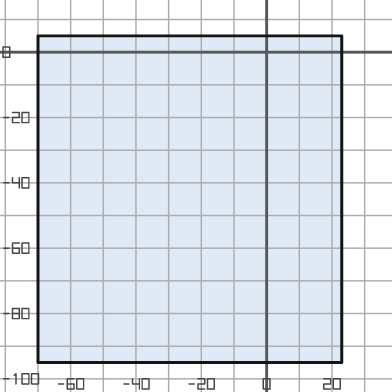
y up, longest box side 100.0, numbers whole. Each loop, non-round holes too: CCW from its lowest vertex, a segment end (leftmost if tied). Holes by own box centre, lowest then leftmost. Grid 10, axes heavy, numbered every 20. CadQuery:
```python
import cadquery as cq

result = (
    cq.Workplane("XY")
    .moveTo(-70.0, -95.0)
    .lineTo(23.0, -95.0)
    .lineTo(23.0, 5.0)
    .lineTo(-70.0, 5.0)
    .close()
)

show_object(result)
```